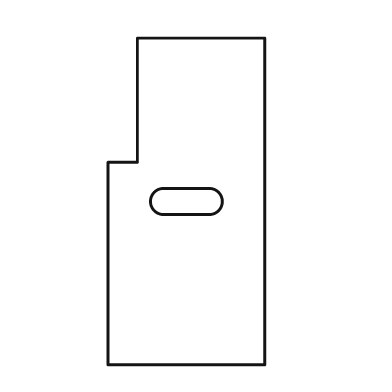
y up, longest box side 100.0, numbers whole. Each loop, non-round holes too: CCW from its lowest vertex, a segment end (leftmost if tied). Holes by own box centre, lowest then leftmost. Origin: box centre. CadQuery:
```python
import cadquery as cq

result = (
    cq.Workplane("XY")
    .moveTo(-24.0, -50.0)
    .lineTo(24.0, -50.0)
    .lineTo(24.0, 50.0)
    .lineTo(-15.0, 50.0)
    .lineTo(-15.0, 12.0)
    .lineTo(-24.0, 12.0)
    .close()
    .moveTo(-7.0, -4.0)
    .lineTo(7.0, -4.0)
    .threePointArc((11.0, 0.0), (7.0, 4.0))
    .lineTo(-7.0, 4.0)
    .threePointArc((-11.0, 0.0), (-7.0, -4.0))
    .close()
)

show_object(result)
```